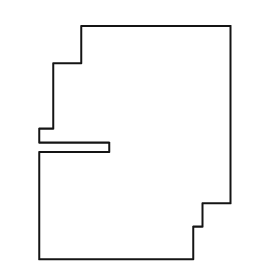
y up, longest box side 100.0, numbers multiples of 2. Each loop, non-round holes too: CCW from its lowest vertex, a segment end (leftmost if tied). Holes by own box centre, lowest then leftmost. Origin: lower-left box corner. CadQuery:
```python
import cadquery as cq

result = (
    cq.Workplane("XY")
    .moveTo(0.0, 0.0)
    .lineTo(66.0, 0.0)
    .lineTo(66.0, 14.0)
    .lineTo(70.0, 14.0)
    .lineTo(70.0, 24.0)
    .lineTo(82.0, 24.0)
    .lineTo(82.0, 100.0)
    .lineTo(18.0, 100.0)
    .lineTo(18.0, 84.0)
    .lineTo(6.0, 84.0)
    .lineTo(6.0, 56.0)
    .lineTo(0.0, 56.0)
    .lineTo(0.0, 50.0)
    .lineTo(30.0, 50.0)
    .lineTo(30.0, 46.0)
    .lineTo(0.0, 46.0)
    .close()
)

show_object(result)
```